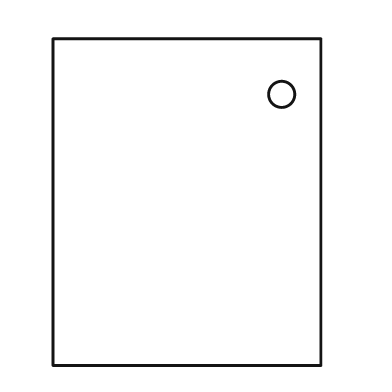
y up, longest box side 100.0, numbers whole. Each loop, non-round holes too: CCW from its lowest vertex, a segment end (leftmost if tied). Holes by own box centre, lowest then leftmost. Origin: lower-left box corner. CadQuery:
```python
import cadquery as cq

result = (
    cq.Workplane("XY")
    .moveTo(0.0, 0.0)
    .lineTo(82.0, 0.0)
    .lineTo(82.0, 100.0)
    .lineTo(0.0, 100.0)
    .close()
    .moveTo(70.0, 83.0)
    .circle(4.0)
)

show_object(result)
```